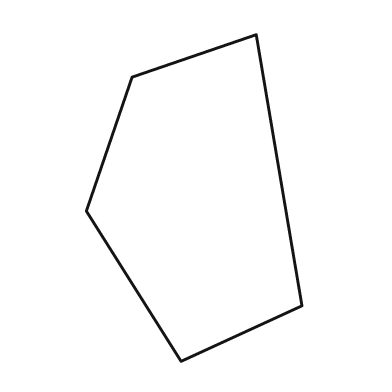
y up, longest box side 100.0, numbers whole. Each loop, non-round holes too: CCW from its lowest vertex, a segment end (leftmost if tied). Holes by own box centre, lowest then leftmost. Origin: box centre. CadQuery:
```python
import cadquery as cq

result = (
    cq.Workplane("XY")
    .moveTo(-4.0, -50.0)
    .lineTo(33.0, -33.0)
    .lineTo(19.0, 50.0)
    .lineTo(-19.0, 37.0)
    .lineTo(-33.0, -4.0)
    .close()
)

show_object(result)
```